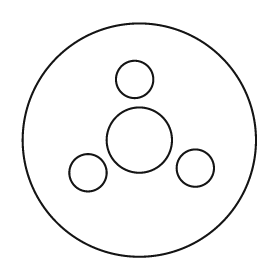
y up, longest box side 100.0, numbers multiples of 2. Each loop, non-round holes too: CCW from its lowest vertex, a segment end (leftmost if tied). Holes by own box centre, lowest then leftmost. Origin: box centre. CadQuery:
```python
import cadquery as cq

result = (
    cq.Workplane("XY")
    .moveTo(0.0, 0.0)
    .circle(50.0)
    .moveTo(-22.0, -14.0)
    .circle(8.0)
    .moveTo(24.0, -12.0)
    .circle(8.0)
    .moveTo(0.0, 0.0)
    .circle(14.0)
    .moveTo(-2.0, 26.0)
    .circle(8.0)
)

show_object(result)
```